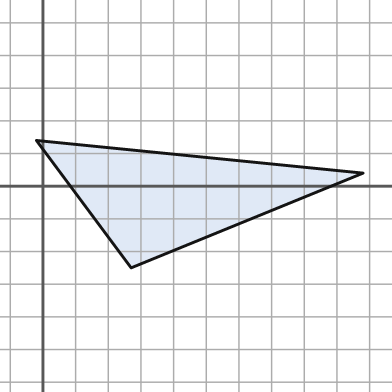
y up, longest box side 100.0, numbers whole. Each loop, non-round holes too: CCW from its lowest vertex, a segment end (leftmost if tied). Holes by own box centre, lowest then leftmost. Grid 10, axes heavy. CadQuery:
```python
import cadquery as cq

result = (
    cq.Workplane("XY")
    .moveTo(27.0, -25.0)
    .lineTo(98.0, 4.0)
    .lineTo(-2.0, 14.0)
    .close()
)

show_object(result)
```